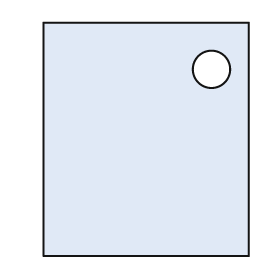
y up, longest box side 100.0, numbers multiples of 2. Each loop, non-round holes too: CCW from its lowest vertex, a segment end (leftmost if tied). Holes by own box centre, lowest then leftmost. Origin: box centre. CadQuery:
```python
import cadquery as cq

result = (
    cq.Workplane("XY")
    .moveTo(-44.0, -50.0)
    .lineTo(44.0, -50.0)
    .lineTo(44.0, 50.0)
    .lineTo(-44.0, 50.0)
    .close()
    .moveTo(28.0, 30.0)
    .circle(8.0)
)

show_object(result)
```